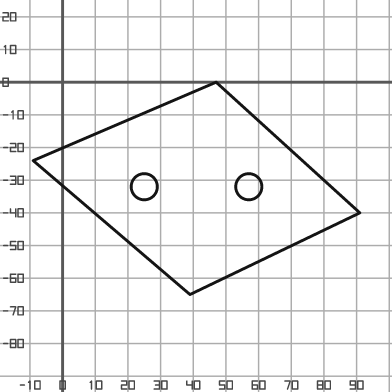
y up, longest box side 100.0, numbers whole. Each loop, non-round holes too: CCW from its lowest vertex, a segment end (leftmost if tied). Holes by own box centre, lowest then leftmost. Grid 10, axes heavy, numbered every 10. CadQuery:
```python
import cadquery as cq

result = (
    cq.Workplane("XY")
    .moveTo(39.0, -65.0)
    .lineTo(91.0, -40.0)
    .lineTo(47.0, 0.0)
    .lineTo(-9.0, -24.0)
    .close()
    .moveTo(25.0, -32.0)
    .circle(4.0)
    .moveTo(57.0, -32.0)
    .circle(4.0)
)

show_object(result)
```